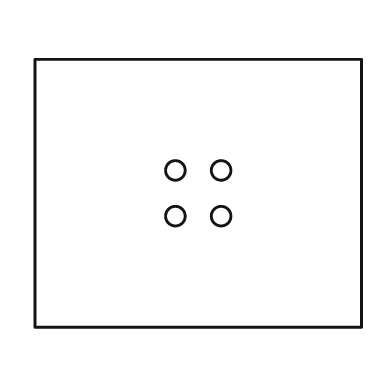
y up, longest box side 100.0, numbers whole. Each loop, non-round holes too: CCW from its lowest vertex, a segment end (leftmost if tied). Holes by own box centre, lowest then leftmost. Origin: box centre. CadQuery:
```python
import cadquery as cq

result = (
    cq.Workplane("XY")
    .moveTo(-50.0, -41.0)
    .lineTo(50.0, -41.0)
    .lineTo(50.0, 41.0)
    .lineTo(-50.0, 41.0)
    .close()
    .moveTo(-7.0, -7.0)
    .circle(3.0)
    .moveTo(7.0, -7.0)
    .circle(3.0)
    .moveTo(-7.0, 7.0)
    .circle(3.0)
    .moveTo(7.0, 7.0)
    .circle(3.0)
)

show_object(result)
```